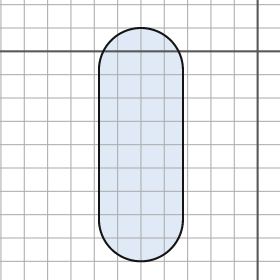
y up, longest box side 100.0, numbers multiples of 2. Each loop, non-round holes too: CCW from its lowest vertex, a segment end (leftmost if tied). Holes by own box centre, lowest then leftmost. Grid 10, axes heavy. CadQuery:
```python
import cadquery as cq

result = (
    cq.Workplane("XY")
    .moveTo(-68.0, -72.0)
    .threePointArc((-50.0, -90.0), (-32.0, -72.0))
    .lineTo(-32.0, -8.0)
    .threePointArc((-50.0, 10.0), (-68.0, -8.0))
    .close()
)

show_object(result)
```